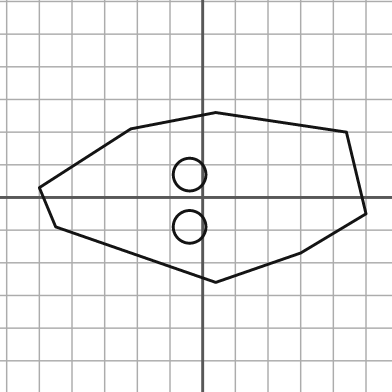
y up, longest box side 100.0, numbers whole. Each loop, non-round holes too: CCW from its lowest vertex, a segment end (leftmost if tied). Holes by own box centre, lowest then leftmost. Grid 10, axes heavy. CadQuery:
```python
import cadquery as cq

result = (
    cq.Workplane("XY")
    .moveTo(4.0, -26.0)
    .lineTo(30.0, -17.0)
    .lineTo(50.0, -5.0)
    .lineTo(44.0, 20.0)
    .lineTo(4.0, 26.0)
    .lineTo(-22.0, 21.0)
    .lineTo(-50.0, 3.0)
    .lineTo(-45.0, -9.0)
    .close()
    .moveTo(-4.0, -9.0)
    .circle(5.0)
    .moveTo(-4.0, 7.0)
    .circle(5.0)
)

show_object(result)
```